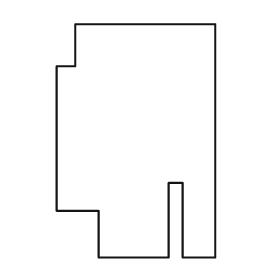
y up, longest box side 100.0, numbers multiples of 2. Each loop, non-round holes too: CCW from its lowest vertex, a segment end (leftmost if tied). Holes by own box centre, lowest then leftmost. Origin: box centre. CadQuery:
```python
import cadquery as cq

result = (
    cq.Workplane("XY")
    .moveTo(-16.0, -50.0)
    .lineTo(14.0, -50.0)
    .lineTo(14.0, -18.0)
    .lineTo(20.0, -18.0)
    .lineTo(20.0, -50.0)
    .lineTo(34.0, -50.0)
    .lineTo(34.0, 50.0)
    .lineTo(-26.0, 50.0)
    .lineTo(-26.0, 32.0)
    .lineTo(-34.0, 32.0)
    .lineTo(-34.0, -30.0)
    .lineTo(-16.0, -30.0)
    .close()
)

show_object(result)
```